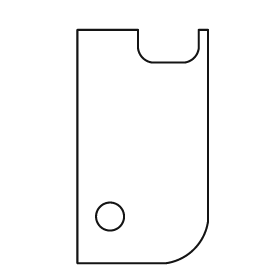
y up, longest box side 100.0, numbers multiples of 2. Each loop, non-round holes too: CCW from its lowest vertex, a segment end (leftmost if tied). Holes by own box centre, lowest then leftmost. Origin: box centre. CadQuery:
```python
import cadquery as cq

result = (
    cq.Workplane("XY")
    .moveTo(-28.0, -50.0)
    .lineTo(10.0, -50.0)
    .threePointArc((22.0, -44.0), (28.0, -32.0))
    .lineTo(28.0, 50.0)
    .lineTo(24.0, 50.0)
    .lineTo(24.0, 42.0)
    .threePointArc((22.0, 38.0), (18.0, 36.0))
    .lineTo(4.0, 36.0)
    .threePointArc((0.0, 38.0), (-2.0, 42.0))
    .lineTo(-2.0, 50.0)
    .lineTo(-28.0, 50.0)
    .close()
    .moveTo(-14.0, -30.0)
    .circle(6.0)
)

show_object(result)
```